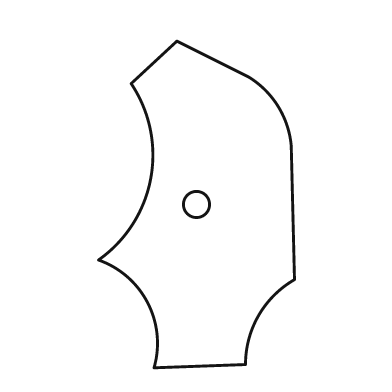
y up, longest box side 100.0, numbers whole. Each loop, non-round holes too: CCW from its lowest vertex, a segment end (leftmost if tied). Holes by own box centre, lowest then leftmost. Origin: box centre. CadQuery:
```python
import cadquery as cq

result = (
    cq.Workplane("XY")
    .moveTo(-13.0, -50.0)
    .lineTo(15.0, -49.0)
    .threePointArc((19.0, -34.0), (30.0, -23.0))
    .lineTo(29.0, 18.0)
    .threePointArc((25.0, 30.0), (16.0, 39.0))
    .lineTo(-6.0, 50.0)
    .lineTo(-20.0, 37.0)
    .threePointArc((-14.0, 8.0), (-30.0, -17.0))
    .threePointArc((-15.0, -30.0), (-13.0, -50.0))
    .close()
    .moveTo(0.0, 0.0)
    .circle(4.0)
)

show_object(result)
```